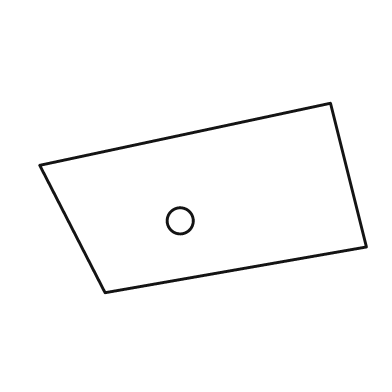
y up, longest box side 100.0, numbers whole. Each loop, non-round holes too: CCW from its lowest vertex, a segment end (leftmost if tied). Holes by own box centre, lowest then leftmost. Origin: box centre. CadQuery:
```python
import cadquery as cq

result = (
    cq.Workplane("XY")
    .moveTo(-30.0, -29.0)
    .lineTo(50.0, -15.0)
    .lineTo(39.0, 29.0)
    .lineTo(-50.0, 10.0)
    .close()
    .moveTo(-7.0, -7.0)
    .circle(4.0)
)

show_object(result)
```